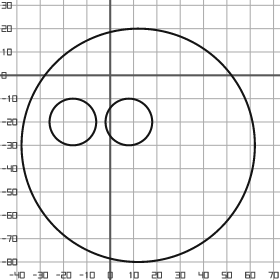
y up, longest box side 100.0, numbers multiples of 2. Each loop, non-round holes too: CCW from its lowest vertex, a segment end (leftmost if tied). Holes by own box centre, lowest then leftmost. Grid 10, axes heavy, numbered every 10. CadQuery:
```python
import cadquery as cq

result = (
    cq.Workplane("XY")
    .moveTo(12.0, -30.0)
    .circle(50.0)
    .moveTo(-16.0, -20.0)
    .circle(10.0)
    .moveTo(8.0, -20.0)
    .circle(10.0)
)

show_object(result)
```